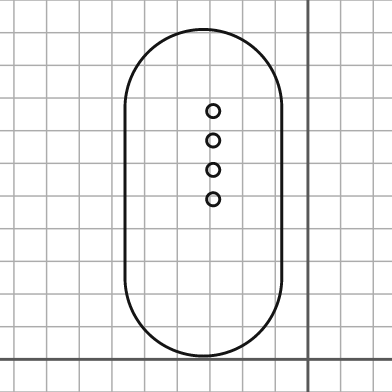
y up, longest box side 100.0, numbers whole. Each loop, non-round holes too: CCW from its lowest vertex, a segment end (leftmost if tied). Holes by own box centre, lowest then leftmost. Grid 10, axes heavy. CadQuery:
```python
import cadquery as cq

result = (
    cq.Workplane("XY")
    .moveTo(-56.0, 25.0)
    .threePointArc((-32.0, 1.0), (-8.0, 25.0))
    .lineTo(-8.0, 77.0)
    .threePointArc((-32.0, 101.0), (-56.0, 77.0))
    .close()
    .moveTo(-29.0, 49.0)
    .circle(2.0)
    .moveTo(-29.0, 58.0)
    .circle(2.0)
    .moveTo(-29.0, 67.0)
    .circle(2.0)
    .moveTo(-29.0, 76.0)
    .circle(2.0)
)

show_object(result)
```